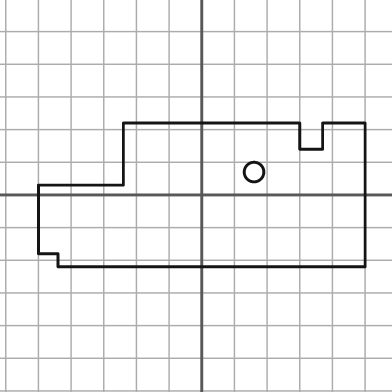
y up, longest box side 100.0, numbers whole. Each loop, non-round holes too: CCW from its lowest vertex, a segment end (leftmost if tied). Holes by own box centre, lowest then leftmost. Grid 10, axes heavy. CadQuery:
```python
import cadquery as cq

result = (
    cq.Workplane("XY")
    .moveTo(-44.0, -22.0)
    .lineTo(50.0, -22.0)
    .lineTo(50.0, 22.0)
    .lineTo(37.0, 22.0)
    .lineTo(37.0, 14.0)
    .lineTo(30.0, 14.0)
    .lineTo(30.0, 22.0)
    .lineTo(-24.0, 22.0)
    .lineTo(-24.0, 3.0)
    .lineTo(-50.0, 3.0)
    .lineTo(-50.0, -18.0)
    .lineTo(-44.0, -18.0)
    .close()
    .moveTo(16.0, 7.0)
    .circle(3.0)
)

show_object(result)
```